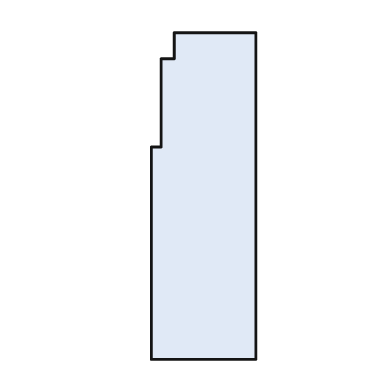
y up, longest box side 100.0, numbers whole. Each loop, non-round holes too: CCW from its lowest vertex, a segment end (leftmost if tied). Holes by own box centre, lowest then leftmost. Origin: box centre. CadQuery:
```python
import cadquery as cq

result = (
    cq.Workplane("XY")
    .moveTo(-16.0, -50.0)
    .lineTo(16.0, -50.0)
    .lineTo(16.0, 50.0)
    .lineTo(-9.0, 50.0)
    .lineTo(-9.0, 42.0)
    .lineTo(-13.0, 42.0)
    .lineTo(-13.0, 15.0)
    .lineTo(-16.0, 15.0)
    .close()
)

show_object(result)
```